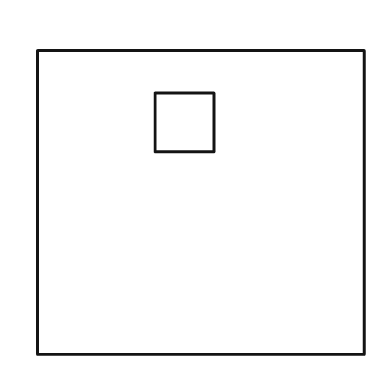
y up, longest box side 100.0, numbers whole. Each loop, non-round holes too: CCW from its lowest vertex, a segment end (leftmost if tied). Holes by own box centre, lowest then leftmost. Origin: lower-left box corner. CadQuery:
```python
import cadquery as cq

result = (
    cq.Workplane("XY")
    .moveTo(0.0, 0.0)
    .lineTo(100.0, 0.0)
    .lineTo(100.0, 93.0)
    .lineTo(0.0, 93.0)
    .close()
    .moveTo(36.0, 62.0)
    .lineTo(54.0, 62.0)
    .lineTo(54.0, 80.0)
    .lineTo(36.0, 80.0)
    .close()
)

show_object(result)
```